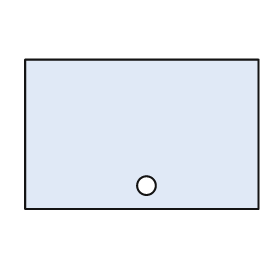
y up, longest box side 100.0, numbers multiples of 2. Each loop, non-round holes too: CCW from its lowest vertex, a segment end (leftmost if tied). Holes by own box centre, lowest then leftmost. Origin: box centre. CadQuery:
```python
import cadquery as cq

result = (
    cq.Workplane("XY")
    .moveTo(-50.0, -32.0)
    .lineTo(50.0, -32.0)
    .lineTo(50.0, 32.0)
    .lineTo(-50.0, 32.0)
    .close()
    .moveTo(2.0, -22.0)
    .circle(4.0)
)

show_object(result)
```